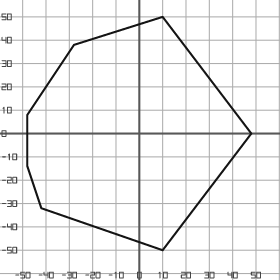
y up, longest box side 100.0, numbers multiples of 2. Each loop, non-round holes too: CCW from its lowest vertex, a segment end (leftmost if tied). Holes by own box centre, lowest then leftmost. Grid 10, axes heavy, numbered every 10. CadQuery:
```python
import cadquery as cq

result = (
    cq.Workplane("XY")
    .moveTo(10.0, -50.0)
    .lineTo(48.0, 0.0)
    .lineTo(10.0, 50.0)
    .lineTo(-28.0, 38.0)
    .lineTo(-48.0, 8.0)
    .lineTo(-48.0, -14.0)
    .lineTo(-42.0, -32.0)
    .close()
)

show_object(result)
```